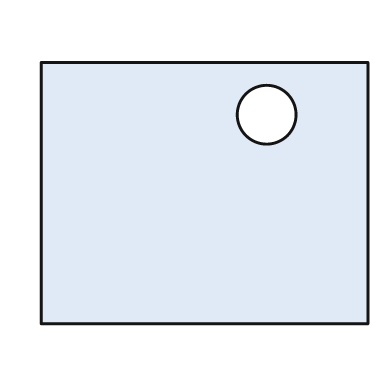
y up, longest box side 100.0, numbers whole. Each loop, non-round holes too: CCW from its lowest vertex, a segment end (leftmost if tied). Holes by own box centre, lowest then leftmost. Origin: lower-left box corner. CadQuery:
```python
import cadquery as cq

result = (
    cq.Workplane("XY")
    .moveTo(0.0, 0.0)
    .lineTo(100.0, 0.0)
    .lineTo(100.0, 80.0)
    .lineTo(0.0, 80.0)
    .close()
    .moveTo(69.0, 64.0)
    .circle(9.0)
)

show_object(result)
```